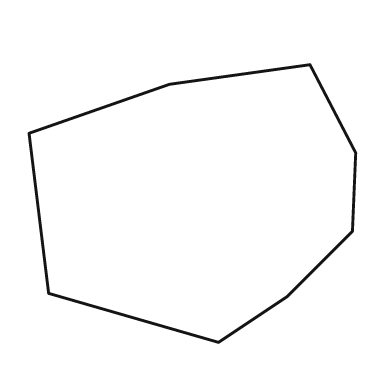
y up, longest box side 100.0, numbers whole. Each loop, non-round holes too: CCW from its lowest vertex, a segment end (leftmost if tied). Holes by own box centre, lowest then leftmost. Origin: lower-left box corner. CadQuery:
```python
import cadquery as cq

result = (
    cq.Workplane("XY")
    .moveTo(58.0, 0.0)
    .lineTo(79.0, 14.0)
    .lineTo(99.0, 34.0)
    .lineTo(100.0, 58.0)
    .lineTo(86.0, 85.0)
    .lineTo(43.0, 79.0)
    .lineTo(0.0, 64.0)
    .lineTo(6.0, 15.0)
    .close()
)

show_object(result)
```